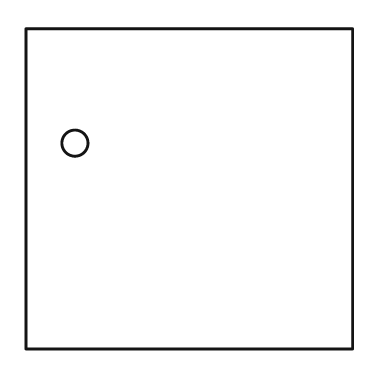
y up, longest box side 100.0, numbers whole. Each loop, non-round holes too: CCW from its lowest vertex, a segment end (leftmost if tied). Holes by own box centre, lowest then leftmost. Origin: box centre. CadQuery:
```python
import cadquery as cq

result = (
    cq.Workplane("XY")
    .moveTo(-50.0, -49.0)
    .lineTo(50.0, -49.0)
    .lineTo(50.0, 49.0)
    .lineTo(-50.0, 49.0)
    .close()
    .moveTo(-35.0, 14.0)
    .circle(4.0)
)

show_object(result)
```